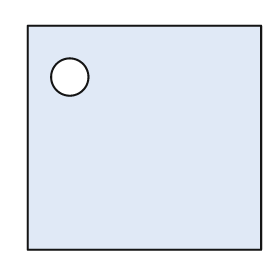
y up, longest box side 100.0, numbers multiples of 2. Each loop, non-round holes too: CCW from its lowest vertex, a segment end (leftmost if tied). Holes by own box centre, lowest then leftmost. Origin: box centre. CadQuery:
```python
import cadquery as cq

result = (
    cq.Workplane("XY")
    .moveTo(-50.0, -48.0)
    .lineTo(50.0, -48.0)
    .lineTo(50.0, 48.0)
    .lineTo(-50.0, 48.0)
    .close()
    .moveTo(-32.0, 26.0)
    .circle(8.0)
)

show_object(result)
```